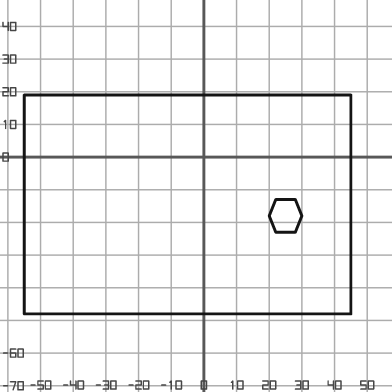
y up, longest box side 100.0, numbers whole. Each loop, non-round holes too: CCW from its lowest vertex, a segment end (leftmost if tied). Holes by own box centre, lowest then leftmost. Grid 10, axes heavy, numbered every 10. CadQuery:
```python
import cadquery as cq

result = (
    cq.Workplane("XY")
    .moveTo(-55.0, -48.0)
    .lineTo(45.0, -48.0)
    .lineTo(45.0, 19.0)
    .lineTo(-55.0, 19.0)
    .close()
    .moveTo(22.0, -23.0)
    .lineTo(28.0, -23.0)
    .lineTo(30.0, -18.0)
    .lineTo(28.0, -13.0)
    .lineTo(22.0, -13.0)
    .lineTo(20.0, -18.0)
    .close()
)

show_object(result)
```